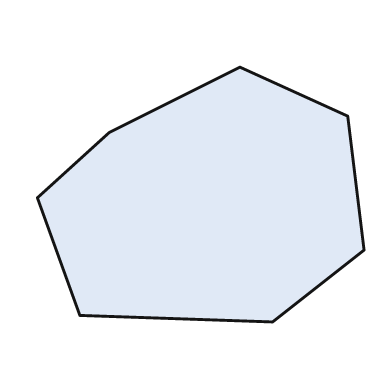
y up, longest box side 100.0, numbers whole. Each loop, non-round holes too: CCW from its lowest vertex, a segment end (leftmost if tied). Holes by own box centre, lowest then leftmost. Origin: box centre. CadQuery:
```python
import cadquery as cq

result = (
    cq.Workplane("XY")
    .moveTo(22.0, -39.0)
    .lineTo(50.0, -17.0)
    .lineTo(45.0, 24.0)
    .lineTo(12.0, 39.0)
    .lineTo(-28.0, 19.0)
    .lineTo(-50.0, -1.0)
    .lineTo(-37.0, -37.0)
    .close()
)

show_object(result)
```